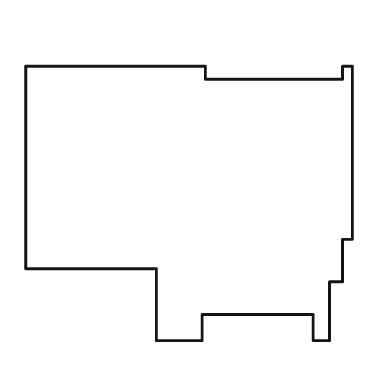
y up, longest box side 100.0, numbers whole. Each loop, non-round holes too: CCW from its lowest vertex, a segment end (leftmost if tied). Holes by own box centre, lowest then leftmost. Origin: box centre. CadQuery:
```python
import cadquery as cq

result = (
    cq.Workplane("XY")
    .moveTo(-10.0, -42.0)
    .lineTo(4.0, -42.0)
    .lineTo(4.0, -34.0)
    .lineTo(38.0, -34.0)
    .lineTo(38.0, -42.0)
    .lineTo(43.0, -42.0)
    .lineTo(43.0, -24.0)
    .lineTo(47.0, -24.0)
    .lineTo(47.0, -11.0)
    .lineTo(50.0, -11.0)
    .lineTo(50.0, 42.0)
    .lineTo(47.0, 42.0)
    .lineTo(47.0, 38.0)
    .lineTo(5.0, 38.0)
    .lineTo(5.0, 42.0)
    .lineTo(-50.0, 42.0)
    .lineTo(-50.0, -20.0)
    .lineTo(-10.0, -20.0)
    .close()
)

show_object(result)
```